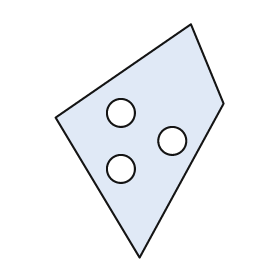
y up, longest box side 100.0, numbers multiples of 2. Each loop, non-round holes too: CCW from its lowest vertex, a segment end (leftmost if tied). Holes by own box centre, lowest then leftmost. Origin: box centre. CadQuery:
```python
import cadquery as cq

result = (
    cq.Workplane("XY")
    .moveTo(0.0, -50.0)
    .lineTo(36.0, 16.0)
    .lineTo(22.0, 50.0)
    .lineTo(-36.0, 10.0)
    .close()
    .moveTo(-8.0, -12.0)
    .circle(6.0)
    .moveTo(14.0, 0.0)
    .circle(6.0)
    .moveTo(-8.0, 12.0)
    .circle(6.0)
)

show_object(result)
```